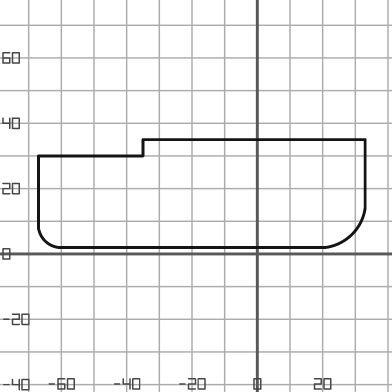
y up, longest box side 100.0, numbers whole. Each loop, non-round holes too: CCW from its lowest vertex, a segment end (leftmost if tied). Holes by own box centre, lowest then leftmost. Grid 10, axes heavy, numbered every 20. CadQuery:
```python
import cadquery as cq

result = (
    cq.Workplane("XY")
    .moveTo(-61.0, 2.0)
    .lineTo(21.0, 2.0)
    .threePointArc((29.0, 6.0), (33.0, 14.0))
    .lineTo(33.0, 35.0)
    .lineTo(-35.0, 35.0)
    .lineTo(-35.0, 30.0)
    .lineTo(-67.0, 30.0)
    .lineTo(-67.0, 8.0)
    .threePointArc((-65.0, 4.0), (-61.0, 2.0))
    .close()
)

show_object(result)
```